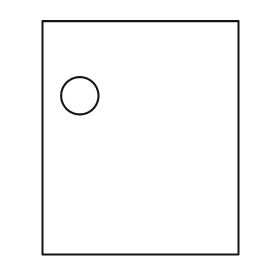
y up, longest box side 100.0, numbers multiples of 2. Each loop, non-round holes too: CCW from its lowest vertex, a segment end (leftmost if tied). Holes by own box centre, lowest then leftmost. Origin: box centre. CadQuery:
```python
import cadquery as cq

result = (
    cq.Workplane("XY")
    .moveTo(-42.0, -50.0)
    .lineTo(42.0, -50.0)
    .lineTo(42.0, 50.0)
    .lineTo(-42.0, 50.0)
    .close()
    .moveTo(-26.0, 18.0)
    .circle(8.0)
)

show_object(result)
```